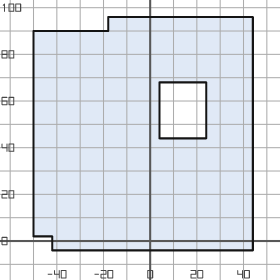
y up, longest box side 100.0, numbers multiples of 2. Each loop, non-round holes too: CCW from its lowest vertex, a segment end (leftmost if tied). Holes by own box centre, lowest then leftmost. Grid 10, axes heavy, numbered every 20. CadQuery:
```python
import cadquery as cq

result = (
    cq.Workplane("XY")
    .moveTo(-42.0, -4.0)
    .lineTo(44.0, -4.0)
    .lineTo(44.0, 96.0)
    .lineTo(-18.0, 96.0)
    .lineTo(-18.0, 90.0)
    .lineTo(-50.0, 90.0)
    .lineTo(-50.0, 2.0)
    .lineTo(-42.0, 2.0)
    .close()
    .moveTo(4.0, 44.0)
    .lineTo(24.0, 44.0)
    .lineTo(24.0, 68.0)
    .lineTo(4.0, 68.0)
    .close()
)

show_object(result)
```